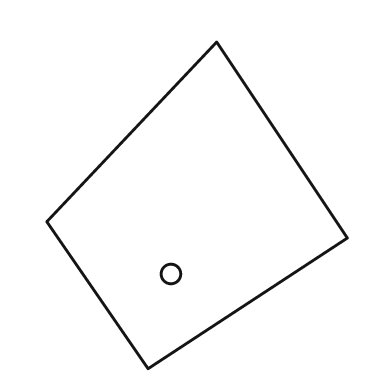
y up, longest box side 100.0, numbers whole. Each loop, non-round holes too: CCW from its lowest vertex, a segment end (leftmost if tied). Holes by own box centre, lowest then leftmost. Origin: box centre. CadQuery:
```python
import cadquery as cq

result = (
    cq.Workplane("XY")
    .moveTo(-15.0, -50.0)
    .lineTo(46.0, -10.0)
    .lineTo(6.0, 50.0)
    .lineTo(-46.0, -5.0)
    .close()
    .moveTo(-8.0, -21.0)
    .circle(3.0)
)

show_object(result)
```